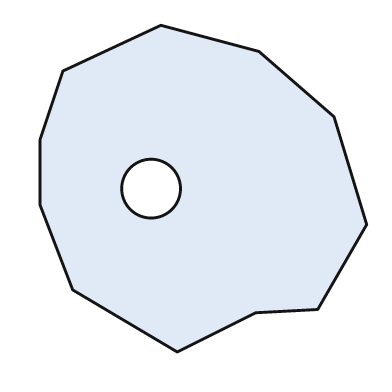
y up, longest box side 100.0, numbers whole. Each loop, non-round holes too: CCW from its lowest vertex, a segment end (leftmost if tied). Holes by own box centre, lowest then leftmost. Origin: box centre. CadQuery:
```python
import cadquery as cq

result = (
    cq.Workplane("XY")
    .moveTo(-8.0, -50.0)
    .lineTo(16.0, -38.0)
    .lineTo(35.0, -37.0)
    .lineTo(50.0, -11.0)
    .lineTo(40.0, 22.0)
    .lineTo(17.0, 42.0)
    .lineTo(-13.0, 50.0)
    .lineTo(-43.0, 36.0)
    .lineTo(-50.0, 15.0)
    .lineTo(-50.0, -5.0)
    .lineTo(-40.0, -31.0)
    .close()
    .moveTo(-16.0, 0.0)
    .circle(9.0)
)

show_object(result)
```